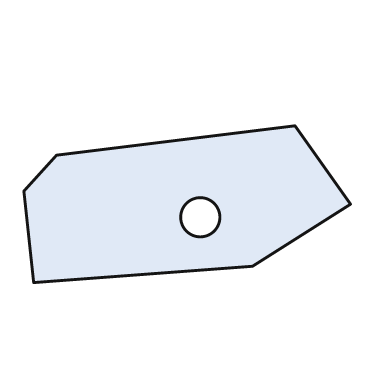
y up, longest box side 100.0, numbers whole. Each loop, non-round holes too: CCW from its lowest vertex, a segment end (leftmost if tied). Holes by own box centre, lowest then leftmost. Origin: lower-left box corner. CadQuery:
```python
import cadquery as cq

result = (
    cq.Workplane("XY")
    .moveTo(3.0, 0.0)
    .lineTo(70.0, 5.0)
    .lineTo(100.0, 24.0)
    .lineTo(83.0, 48.0)
    .lineTo(10.0, 39.0)
    .lineTo(0.0, 28.0)
    .close()
    .moveTo(54.0, 20.0)
    .circle(6.0)
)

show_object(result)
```